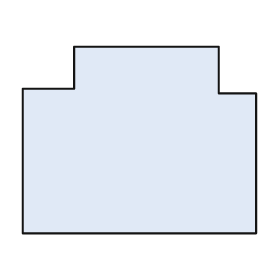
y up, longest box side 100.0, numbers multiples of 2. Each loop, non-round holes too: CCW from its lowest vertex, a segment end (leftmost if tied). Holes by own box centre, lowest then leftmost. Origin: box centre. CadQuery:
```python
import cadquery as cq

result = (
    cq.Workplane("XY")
    .moveTo(-50.0, -40.0)
    .lineTo(50.0, -40.0)
    .lineTo(50.0, 20.0)
    .lineTo(34.0, 20.0)
    .lineTo(34.0, 40.0)
    .lineTo(-28.0, 40.0)
    .lineTo(-28.0, 22.0)
    .lineTo(-50.0, 22.0)
    .close()
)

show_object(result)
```